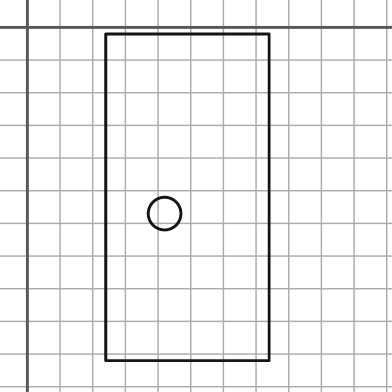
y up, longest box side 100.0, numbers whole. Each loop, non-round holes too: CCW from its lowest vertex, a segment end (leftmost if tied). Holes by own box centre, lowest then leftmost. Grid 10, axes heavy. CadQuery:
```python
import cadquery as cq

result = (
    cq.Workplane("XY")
    .moveTo(24.0, -102.0)
    .lineTo(74.0, -102.0)
    .lineTo(74.0, -2.0)
    .lineTo(24.0, -2.0)
    .close()
    .moveTo(42.0, -57.0)
    .circle(5.0)
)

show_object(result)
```